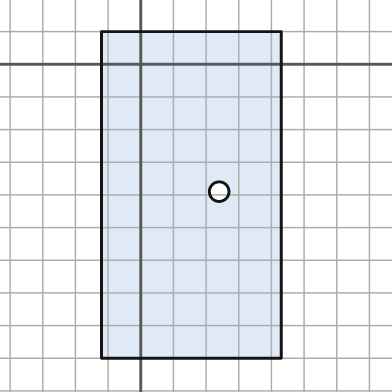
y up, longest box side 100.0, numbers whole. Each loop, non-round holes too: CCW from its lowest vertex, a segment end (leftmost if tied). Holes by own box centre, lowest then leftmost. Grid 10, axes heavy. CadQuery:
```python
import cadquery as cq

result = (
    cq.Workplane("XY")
    .moveTo(-12.0, -90.0)
    .lineTo(43.0, -90.0)
    .lineTo(43.0, 10.0)
    .lineTo(-12.0, 10.0)
    .close()
    .moveTo(24.0, -39.0)
    .circle(3.0)
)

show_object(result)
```